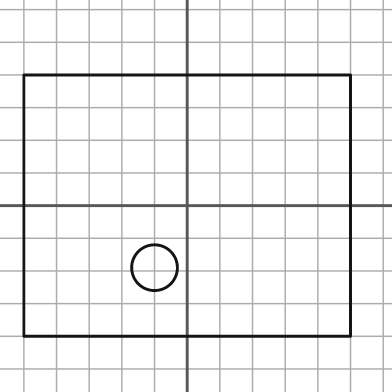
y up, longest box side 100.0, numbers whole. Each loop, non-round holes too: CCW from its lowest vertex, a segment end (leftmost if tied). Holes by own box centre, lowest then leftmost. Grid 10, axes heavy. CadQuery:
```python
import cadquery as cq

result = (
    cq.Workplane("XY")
    .moveTo(-50.0, -40.0)
    .lineTo(50.0, -40.0)
    .lineTo(50.0, 40.0)
    .lineTo(-50.0, 40.0)
    .close()
    .moveTo(-10.0, -19.0)
    .circle(7.0)
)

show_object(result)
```